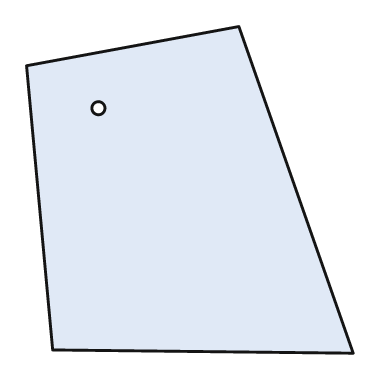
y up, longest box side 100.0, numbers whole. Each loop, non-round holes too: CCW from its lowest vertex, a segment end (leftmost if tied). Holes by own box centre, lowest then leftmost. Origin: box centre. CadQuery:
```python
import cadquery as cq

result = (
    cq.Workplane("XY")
    .moveTo(50.0, -50.0)
    .lineTo(15.0, 50.0)
    .lineTo(-50.0, 38.0)
    .lineTo(-42.0, -49.0)
    .close()
    .moveTo(-28.0, 25.0)
    .circle(2.0)
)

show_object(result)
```